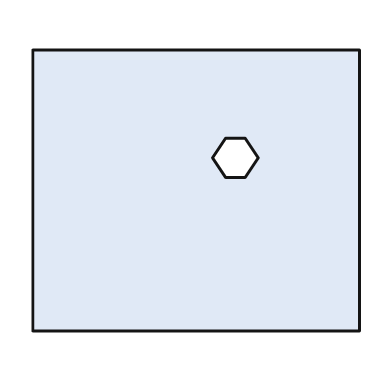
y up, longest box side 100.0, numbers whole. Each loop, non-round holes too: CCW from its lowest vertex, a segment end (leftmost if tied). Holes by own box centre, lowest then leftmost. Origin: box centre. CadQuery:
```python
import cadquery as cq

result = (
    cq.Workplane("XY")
    .moveTo(-50.0, -43.0)
    .lineTo(50.0, -43.0)
    .lineTo(50.0, 43.0)
    .lineTo(-50.0, 43.0)
    .close()
    .moveTo(9.0, 4.0)
    .lineTo(15.0, 4.0)
    .lineTo(19.0, 10.0)
    .lineTo(15.0, 16.0)
    .lineTo(9.0, 16.0)
    .lineTo(5.0, 10.0)
    .close()
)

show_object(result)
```